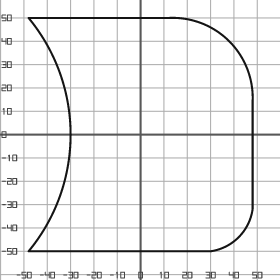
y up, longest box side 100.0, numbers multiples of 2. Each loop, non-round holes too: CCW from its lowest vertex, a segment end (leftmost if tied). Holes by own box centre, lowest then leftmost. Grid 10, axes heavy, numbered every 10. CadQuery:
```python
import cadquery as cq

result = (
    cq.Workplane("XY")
    .moveTo(-48.0, -50.0)
    .lineTo(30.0, -50.0)
    .threePointArc((42.0, -44.0), (48.0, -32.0))
    .lineTo(48.0, 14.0)
    .threePointArc((38.0, 40.0), (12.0, 50.0))
    .lineTo(-48.0, 50.0)
    .threePointArc((-30.0, 0.0), (-48.0, -50.0))
    .close()
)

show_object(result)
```